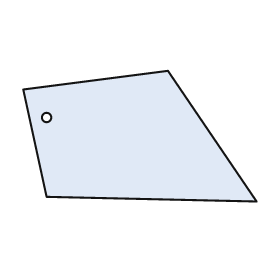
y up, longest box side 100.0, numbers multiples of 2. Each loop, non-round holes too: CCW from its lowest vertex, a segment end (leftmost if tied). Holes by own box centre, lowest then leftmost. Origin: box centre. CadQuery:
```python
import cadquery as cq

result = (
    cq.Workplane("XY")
    .moveTo(50.0, -28.0)
    .lineTo(12.0, 28.0)
    .lineTo(-50.0, 20.0)
    .lineTo(-40.0, -26.0)
    .close()
    .moveTo(-40.0, 8.0)
    .circle(2.0)
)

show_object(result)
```